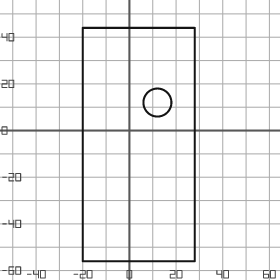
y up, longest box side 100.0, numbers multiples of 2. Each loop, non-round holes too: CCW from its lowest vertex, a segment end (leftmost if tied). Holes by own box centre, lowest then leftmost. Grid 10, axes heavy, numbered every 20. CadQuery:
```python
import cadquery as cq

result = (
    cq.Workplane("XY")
    .moveTo(-20.0, -56.0)
    .lineTo(28.0, -56.0)
    .lineTo(28.0, 44.0)
    .lineTo(-20.0, 44.0)
    .close()
    .moveTo(12.0, 12.0)
    .circle(6.0)
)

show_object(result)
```